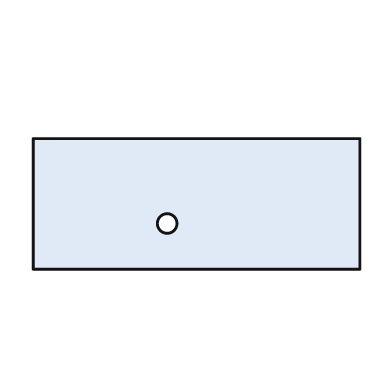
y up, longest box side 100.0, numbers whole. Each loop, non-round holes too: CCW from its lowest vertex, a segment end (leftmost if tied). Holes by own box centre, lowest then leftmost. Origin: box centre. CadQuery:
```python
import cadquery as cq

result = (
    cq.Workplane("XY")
    .moveTo(-50.0, -20.0)
    .lineTo(50.0, -20.0)
    .lineTo(50.0, 20.0)
    .lineTo(-50.0, 20.0)
    .close()
    .moveTo(-9.0, -6.0)
    .circle(3.0)
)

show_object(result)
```